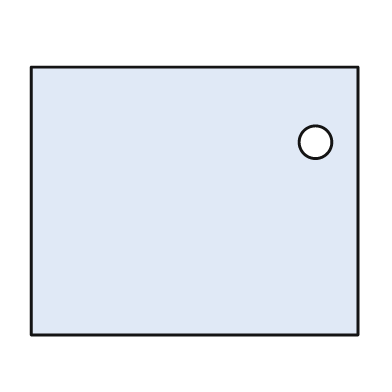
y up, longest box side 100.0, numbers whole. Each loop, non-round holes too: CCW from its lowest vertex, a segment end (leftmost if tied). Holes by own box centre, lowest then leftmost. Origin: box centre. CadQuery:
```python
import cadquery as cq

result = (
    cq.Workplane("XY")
    .moveTo(-50.0, -41.0)
    .lineTo(50.0, -41.0)
    .lineTo(50.0, 41.0)
    .lineTo(-50.0, 41.0)
    .close()
    .moveTo(37.0, 18.0)
    .circle(5.0)
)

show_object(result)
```